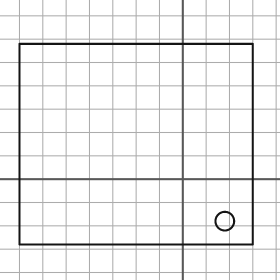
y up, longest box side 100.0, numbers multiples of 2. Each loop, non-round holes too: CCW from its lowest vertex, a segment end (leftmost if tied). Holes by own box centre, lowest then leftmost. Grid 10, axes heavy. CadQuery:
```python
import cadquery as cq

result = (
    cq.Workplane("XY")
    .moveTo(-70.0, -28.0)
    .lineTo(30.0, -28.0)
    .lineTo(30.0, 58.0)
    .lineTo(-70.0, 58.0)
    .close()
    .moveTo(18.0, -18.0)
    .circle(4.0)
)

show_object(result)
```